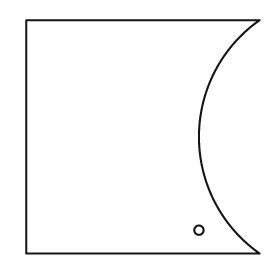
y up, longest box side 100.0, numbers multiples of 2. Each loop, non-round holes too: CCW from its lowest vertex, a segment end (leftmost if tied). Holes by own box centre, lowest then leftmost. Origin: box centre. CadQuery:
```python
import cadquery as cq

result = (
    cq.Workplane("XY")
    .moveTo(-50.0, -50.0)
    .lineTo(50.0, -50.0)
    .threePointArc((24.0, 0.0), (50.0, 50.0))
    .lineTo(-50.0, 50.0)
    .close()
    .moveTo(24.0, -40.0)
    .circle(2.0)
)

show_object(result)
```